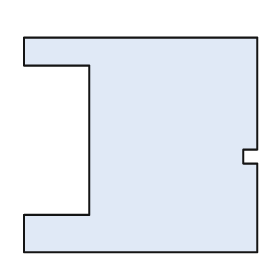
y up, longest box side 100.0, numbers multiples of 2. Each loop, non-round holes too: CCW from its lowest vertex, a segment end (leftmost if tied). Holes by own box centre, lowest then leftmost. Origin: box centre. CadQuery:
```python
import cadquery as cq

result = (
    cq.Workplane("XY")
    .moveTo(-50.0, -46.0)
    .lineTo(50.0, -46.0)
    .lineTo(50.0, -8.0)
    .lineTo(44.0, -8.0)
    .lineTo(44.0, -2.0)
    .lineTo(50.0, -2.0)
    .lineTo(50.0, 46.0)
    .lineTo(-50.0, 46.0)
    .lineTo(-50.0, 34.0)
    .lineTo(-22.0, 34.0)
    .lineTo(-22.0, -30.0)
    .lineTo(-50.0, -30.0)
    .close()
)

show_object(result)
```